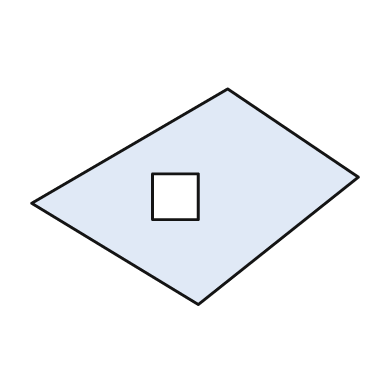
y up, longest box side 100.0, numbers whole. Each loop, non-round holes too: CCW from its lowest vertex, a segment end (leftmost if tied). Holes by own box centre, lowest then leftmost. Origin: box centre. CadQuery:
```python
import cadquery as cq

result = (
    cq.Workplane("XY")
    .moveTo(1.0, -33.0)
    .lineTo(50.0, 6.0)
    .lineTo(10.0, 33.0)
    .lineTo(-50.0, -2.0)
    .close()
    .moveTo(-13.0, -7.0)
    .lineTo(1.0, -7.0)
    .lineTo(1.0, 7.0)
    .lineTo(-13.0, 7.0)
    .close()
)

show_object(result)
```